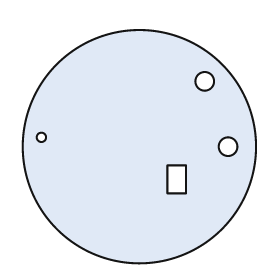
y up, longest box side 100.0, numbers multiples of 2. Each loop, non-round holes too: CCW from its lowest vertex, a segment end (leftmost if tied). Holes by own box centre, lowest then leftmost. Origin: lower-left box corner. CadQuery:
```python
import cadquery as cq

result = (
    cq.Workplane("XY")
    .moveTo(50.0, 50.0)
    .circle(50.0)
    .moveTo(62.0, 30.0)
    .lineTo(70.0, 30.0)
    .lineTo(70.0, 42.0)
    .lineTo(62.0, 42.0)
    .close()
    .moveTo(88.0, 50.0)
    .circle(4.0)
    .moveTo(8.0, 54.0)
    .circle(2.0)
    .moveTo(78.0, 78.0)
    .circle(4.0)
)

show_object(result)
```